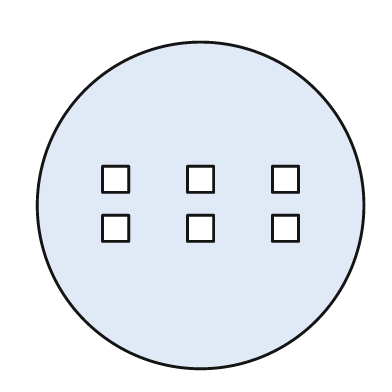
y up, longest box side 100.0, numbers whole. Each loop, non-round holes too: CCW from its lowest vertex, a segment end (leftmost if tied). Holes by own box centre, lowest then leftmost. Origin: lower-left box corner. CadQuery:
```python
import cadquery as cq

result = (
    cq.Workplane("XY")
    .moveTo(50.0, 50.0)
    .circle(50.0)
    .moveTo(20.0, 39.0)
    .lineTo(28.0, 39.0)
    .lineTo(28.0, 47.0)
    .lineTo(20.0, 47.0)
    .close()
    .moveTo(46.0, 39.0)
    .lineTo(54.0, 39.0)
    .lineTo(54.0, 47.0)
    .lineTo(46.0, 47.0)
    .close()
    .moveTo(72.0, 39.0)
    .lineTo(80.0, 39.0)
    .lineTo(80.0, 47.0)
    .lineTo(72.0, 47.0)
    .close()
    .moveTo(20.0, 54.0)
    .lineTo(28.0, 54.0)
    .lineTo(28.0, 62.0)
    .lineTo(20.0, 62.0)
    .close()
    .moveTo(46.0, 54.0)
    .lineTo(54.0, 54.0)
    .lineTo(54.0, 62.0)
    .lineTo(46.0, 62.0)
    .close()
    .moveTo(72.0, 54.0)
    .lineTo(80.0, 54.0)
    .lineTo(80.0, 62.0)
    .lineTo(72.0, 62.0)
    .close()
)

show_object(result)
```